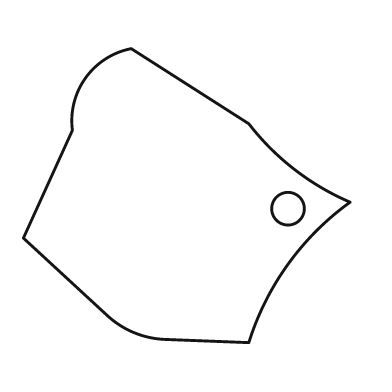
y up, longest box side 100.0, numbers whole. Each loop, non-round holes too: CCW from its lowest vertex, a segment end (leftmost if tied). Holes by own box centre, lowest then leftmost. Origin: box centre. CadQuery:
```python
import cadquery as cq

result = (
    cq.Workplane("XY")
    .moveTo(19.0, -45.0)
    .threePointArc((31.0, -21.0), (50.0, -2.0))
    .threePointArc((33.0, 8.0), (19.0, 22.0))
    .lineTo(-17.0, 45.0)
    .threePointArc((-31.0, 36.0), (-35.0, 20.0))
    .lineTo(-50.0, -13.0)
    .lineTo(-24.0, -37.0)
    .threePointArc((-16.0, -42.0), (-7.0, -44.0))
    .close()
    .moveTo(31.0, -4.0)
    .circle(5.0)
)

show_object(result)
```